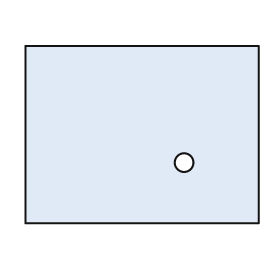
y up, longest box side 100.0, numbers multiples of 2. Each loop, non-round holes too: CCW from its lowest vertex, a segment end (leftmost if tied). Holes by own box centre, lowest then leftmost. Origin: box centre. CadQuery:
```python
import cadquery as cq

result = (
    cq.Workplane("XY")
    .moveTo(-50.0, -38.0)
    .lineTo(50.0, -38.0)
    .lineTo(50.0, 38.0)
    .lineTo(-50.0, 38.0)
    .close()
    .moveTo(18.0, -12.0)
    .circle(4.0)
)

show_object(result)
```